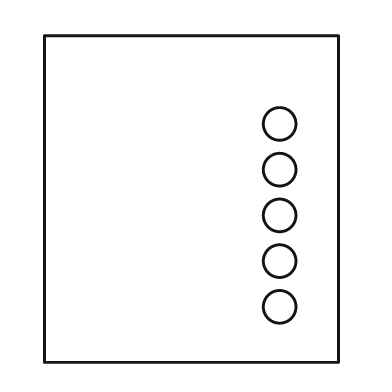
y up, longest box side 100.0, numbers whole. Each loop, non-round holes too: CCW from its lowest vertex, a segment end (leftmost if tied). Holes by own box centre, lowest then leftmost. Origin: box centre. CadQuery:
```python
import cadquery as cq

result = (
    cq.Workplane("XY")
    .moveTo(-45.0, -50.0)
    .lineTo(45.0, -50.0)
    .lineTo(45.0, 50.0)
    .lineTo(-45.0, 50.0)
    .close()
    .moveTo(27.0, -33.0)
    .circle(5.0)
    .moveTo(27.0, -19.0)
    .circle(5.0)
    .moveTo(27.0, -5.0)
    .circle(5.0)
    .moveTo(27.0, 9.0)
    .circle(5.0)
    .moveTo(27.0, 23.0)
    .circle(5.0)
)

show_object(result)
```